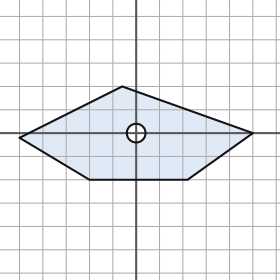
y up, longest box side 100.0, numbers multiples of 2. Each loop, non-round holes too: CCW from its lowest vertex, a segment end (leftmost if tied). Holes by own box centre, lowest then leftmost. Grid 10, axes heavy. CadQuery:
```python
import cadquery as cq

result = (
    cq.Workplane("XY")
    .moveTo(-20.0, -20.0)
    .lineTo(22.0, -20.0)
    .lineTo(50.0, 0.0)
    .lineTo(-6.0, 20.0)
    .lineTo(-50.0, -2.0)
    .close()
    .moveTo(0.0, 0.0)
    .circle(4.0)
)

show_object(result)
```